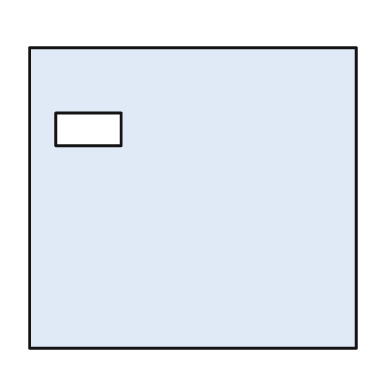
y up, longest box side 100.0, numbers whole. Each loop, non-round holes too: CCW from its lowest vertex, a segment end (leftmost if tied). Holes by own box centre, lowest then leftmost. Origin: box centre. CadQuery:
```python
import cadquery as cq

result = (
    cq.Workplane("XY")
    .moveTo(-50.0, -46.0)
    .lineTo(50.0, -46.0)
    .lineTo(50.0, 46.0)
    .lineTo(-50.0, 46.0)
    .close()
    .moveTo(-42.0, 16.0)
    .lineTo(-22.0, 16.0)
    .lineTo(-22.0, 26.0)
    .lineTo(-42.0, 26.0)
    .close()
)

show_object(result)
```